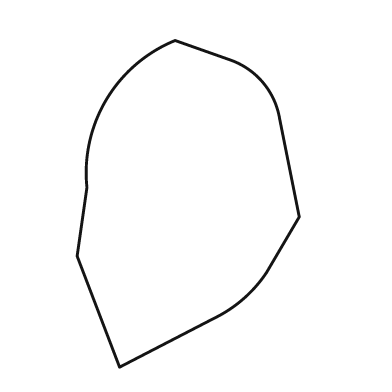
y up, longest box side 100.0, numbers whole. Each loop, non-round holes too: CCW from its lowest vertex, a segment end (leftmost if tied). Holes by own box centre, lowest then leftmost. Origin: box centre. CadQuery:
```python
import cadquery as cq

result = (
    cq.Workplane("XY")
    .moveTo(-21.0, -50.0)
    .lineTo(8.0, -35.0)
    .threePointArc((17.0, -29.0), (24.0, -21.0))
    .lineTo(34.0, -4.0)
    .lineTo(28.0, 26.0)
    .threePointArc((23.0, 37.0), (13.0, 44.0))
    .lineTo(-4.0, 50.0)
    .threePointArc((-25.0, 32.0), (-31.0, 5.0))
    .lineTo(-34.0, -16.0)
    .close()
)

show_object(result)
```